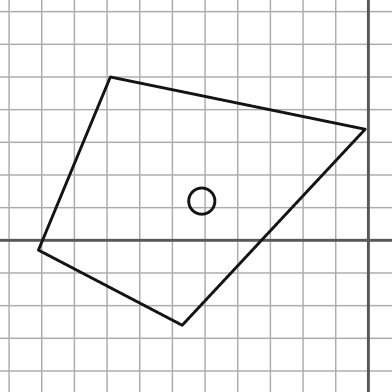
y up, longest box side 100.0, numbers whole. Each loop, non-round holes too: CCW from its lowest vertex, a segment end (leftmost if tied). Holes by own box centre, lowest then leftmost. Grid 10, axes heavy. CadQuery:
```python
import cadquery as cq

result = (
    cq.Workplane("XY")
    .moveTo(-57.0, -26.0)
    .lineTo(-1.0, 34.0)
    .lineTo(-79.0, 50.0)
    .lineTo(-101.0, -3.0)
    .close()
    .moveTo(-51.0, 12.0)
    .circle(4.0)
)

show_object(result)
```